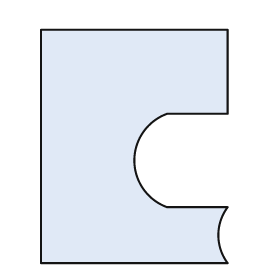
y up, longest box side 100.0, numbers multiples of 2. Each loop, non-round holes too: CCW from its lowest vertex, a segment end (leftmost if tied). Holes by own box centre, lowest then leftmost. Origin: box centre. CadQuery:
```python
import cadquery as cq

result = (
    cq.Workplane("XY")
    .moveTo(-40.0, -50.0)
    .lineTo(40.0, -50.0)
    .threePointArc((36.0, -38.0), (40.0, -26.0))
    .lineTo(14.0, -26.0)
    .threePointArc((0.0, -6.0), (14.0, 14.0))
    .lineTo(40.0, 14.0)
    .lineTo(40.0, 50.0)
    .lineTo(-40.0, 50.0)
    .close()
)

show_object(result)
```